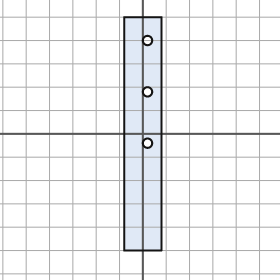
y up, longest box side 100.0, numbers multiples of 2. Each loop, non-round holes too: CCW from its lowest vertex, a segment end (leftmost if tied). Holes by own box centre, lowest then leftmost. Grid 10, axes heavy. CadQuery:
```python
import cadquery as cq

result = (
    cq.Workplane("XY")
    .moveTo(-8.0, -50.0)
    .lineTo(8.0, -50.0)
    .lineTo(8.0, 50.0)
    .lineTo(-8.0, 50.0)
    .close()
    .moveTo(2.0, -4.0)
    .circle(2.0)
    .moveTo(2.0, 18.0)
    .circle(2.0)
    .moveTo(2.0, 40.0)
    .circle(2.0)
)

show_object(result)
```